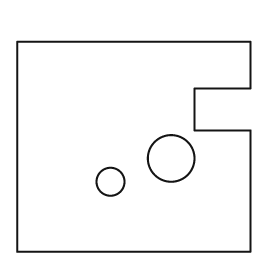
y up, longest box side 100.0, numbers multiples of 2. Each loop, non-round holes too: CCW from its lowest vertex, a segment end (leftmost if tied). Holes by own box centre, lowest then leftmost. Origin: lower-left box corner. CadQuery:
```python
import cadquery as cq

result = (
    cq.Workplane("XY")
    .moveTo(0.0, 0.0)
    .lineTo(100.0, 0.0)
    .lineTo(100.0, 52.0)
    .lineTo(76.0, 52.0)
    .lineTo(76.0, 70.0)
    .lineTo(100.0, 70.0)
    .lineTo(100.0, 90.0)
    .lineTo(0.0, 90.0)
    .close()
    .moveTo(40.0, 30.0)
    .circle(6.0)
    .moveTo(66.0, 40.0)
    .circle(10.0)
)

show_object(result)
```